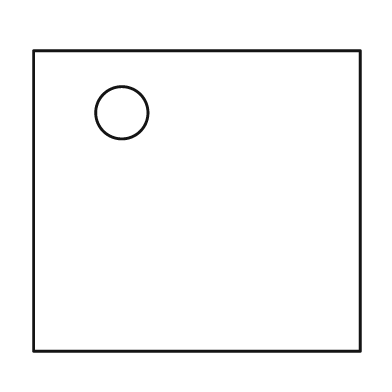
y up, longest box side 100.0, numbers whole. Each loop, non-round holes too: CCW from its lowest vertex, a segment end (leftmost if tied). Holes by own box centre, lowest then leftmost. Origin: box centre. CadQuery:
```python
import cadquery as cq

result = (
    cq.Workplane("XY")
    .moveTo(-50.0, -46.0)
    .lineTo(50.0, -46.0)
    .lineTo(50.0, 46.0)
    .lineTo(-50.0, 46.0)
    .close()
    .moveTo(-23.0, 27.0)
    .circle(8.0)
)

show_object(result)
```